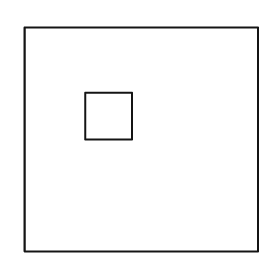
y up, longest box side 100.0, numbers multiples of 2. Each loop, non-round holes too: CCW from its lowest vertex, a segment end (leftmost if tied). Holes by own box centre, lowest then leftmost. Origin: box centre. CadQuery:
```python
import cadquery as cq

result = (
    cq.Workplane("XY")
    .moveTo(-50.0, -48.0)
    .lineTo(50.0, -48.0)
    .lineTo(50.0, 48.0)
    .lineTo(-50.0, 48.0)
    .close()
    .moveTo(-24.0, 0.0)
    .lineTo(-4.0, 0.0)
    .lineTo(-4.0, 20.0)
    .lineTo(-24.0, 20.0)
    .close()
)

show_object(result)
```